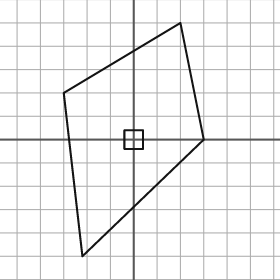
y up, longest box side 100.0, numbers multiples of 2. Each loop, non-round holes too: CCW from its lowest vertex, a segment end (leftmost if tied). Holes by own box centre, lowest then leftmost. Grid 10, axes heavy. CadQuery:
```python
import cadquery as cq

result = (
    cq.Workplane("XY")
    .moveTo(-22.0, -50.0)
    .lineTo(30.0, 0.0)
    .lineTo(20.0, 50.0)
    .lineTo(-30.0, 20.0)
    .close()
    .moveTo(-4.0, -4.0)
    .lineTo(4.0, -4.0)
    .lineTo(4.0, 4.0)
    .lineTo(-4.0, 4.0)
    .close()
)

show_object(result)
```